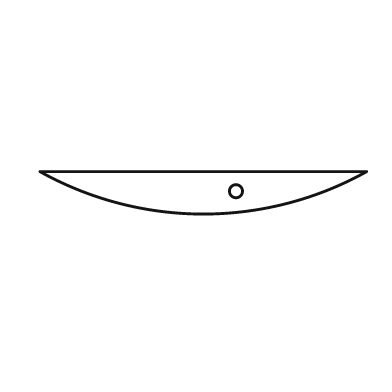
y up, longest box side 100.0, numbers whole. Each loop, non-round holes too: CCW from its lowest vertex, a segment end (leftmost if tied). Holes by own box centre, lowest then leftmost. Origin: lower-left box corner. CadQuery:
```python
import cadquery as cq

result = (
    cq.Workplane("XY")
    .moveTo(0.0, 13.0)
    .threePointArc((50.0, 0.0), (100.0, 13.0))
    .close()
    .moveTo(60.0, 7.0)
    .circle(2.0)
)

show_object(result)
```